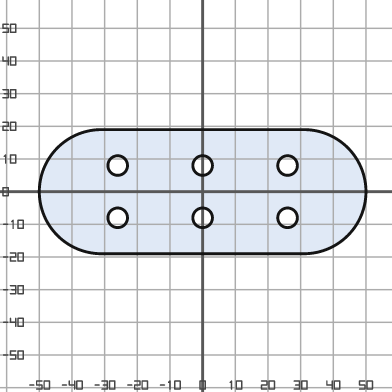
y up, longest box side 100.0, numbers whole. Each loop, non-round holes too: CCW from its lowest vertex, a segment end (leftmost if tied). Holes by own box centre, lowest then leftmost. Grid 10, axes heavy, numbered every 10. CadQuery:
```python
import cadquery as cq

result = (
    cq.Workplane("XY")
    .moveTo(-31.0, -19.0)
    .lineTo(31.0, -19.0)
    .threePointArc((50.0, 0.0), (31.0, 19.0))
    .lineTo(-31.0, 19.0)
    .threePointArc((-50.0, 0.0), (-31.0, -19.0))
    .close()
    .moveTo(-26.0, -8.0)
    .circle(3.0)
    .moveTo(0.0, -8.0)
    .circle(3.0)
    .moveTo(26.0, -8.0)
    .circle(3.0)
    .moveTo(-26.0, 8.0)
    .circle(3.0)
    .moveTo(0.0, 8.0)
    .circle(3.0)
    .moveTo(26.0, 8.0)
    .circle(3.0)
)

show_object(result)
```